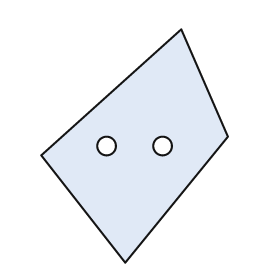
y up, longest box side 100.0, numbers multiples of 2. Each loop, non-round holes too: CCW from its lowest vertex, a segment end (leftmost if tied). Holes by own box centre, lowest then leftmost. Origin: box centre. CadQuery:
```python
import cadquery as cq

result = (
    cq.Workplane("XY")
    .moveTo(-4.0, -50.0)
    .lineTo(40.0, 4.0)
    .lineTo(20.0, 50.0)
    .lineTo(-40.0, -4.0)
    .close()
    .moveTo(-12.0, 0.0)
    .circle(4.0)
    .moveTo(12.0, 0.0)
    .circle(4.0)
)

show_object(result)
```